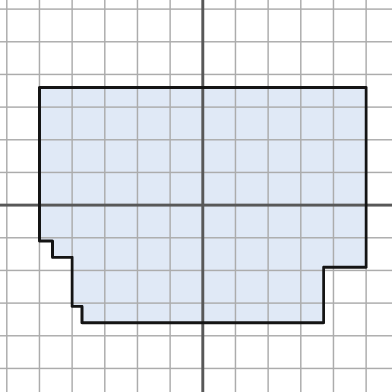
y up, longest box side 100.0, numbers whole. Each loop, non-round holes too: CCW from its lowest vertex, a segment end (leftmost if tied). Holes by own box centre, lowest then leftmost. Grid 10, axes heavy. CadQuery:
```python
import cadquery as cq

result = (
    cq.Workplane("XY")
    .moveTo(-37.0, -36.0)
    .lineTo(37.0, -36.0)
    .lineTo(37.0, -19.0)
    .lineTo(50.0, -19.0)
    .lineTo(50.0, 36.0)
    .lineTo(-50.0, 36.0)
    .lineTo(-50.0, -11.0)
    .lineTo(-46.0, -11.0)
    .lineTo(-46.0, -16.0)
    .lineTo(-40.0, -16.0)
    .lineTo(-40.0, -31.0)
    .lineTo(-37.0, -31.0)
    .close()
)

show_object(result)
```